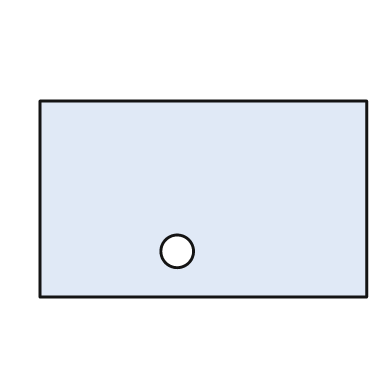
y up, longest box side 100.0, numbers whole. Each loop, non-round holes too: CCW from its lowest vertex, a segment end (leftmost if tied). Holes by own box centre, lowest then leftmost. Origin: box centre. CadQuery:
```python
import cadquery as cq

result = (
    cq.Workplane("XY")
    .moveTo(-50.0, -30.0)
    .lineTo(50.0, -30.0)
    .lineTo(50.0, 30.0)
    .lineTo(-50.0, 30.0)
    .close()
    .moveTo(-8.0, -16.0)
    .circle(5.0)
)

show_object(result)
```